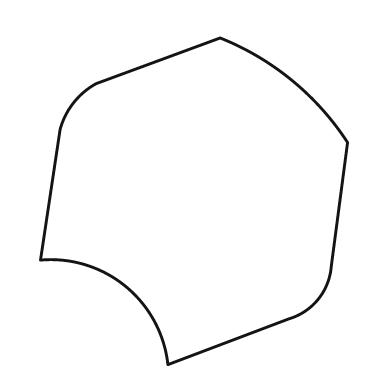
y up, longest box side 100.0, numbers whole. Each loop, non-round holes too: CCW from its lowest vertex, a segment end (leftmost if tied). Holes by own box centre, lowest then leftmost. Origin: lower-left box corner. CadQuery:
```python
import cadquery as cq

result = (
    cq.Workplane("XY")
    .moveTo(39.0, 0.0)
    .lineTo(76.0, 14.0)
    .threePointArc((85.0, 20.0), (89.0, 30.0))
    .lineTo(94.0, 68.0)
    .threePointArc((77.0, 87.0), (55.0, 100.0))
    .lineTo(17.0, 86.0)
    .threePointArc((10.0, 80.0), (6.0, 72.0))
    .lineTo(0.0, 32.0)
    .threePointArc((26.0, 24.0), (39.0, 0.0))
    .close()
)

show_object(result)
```